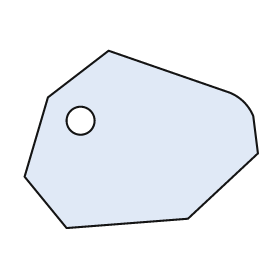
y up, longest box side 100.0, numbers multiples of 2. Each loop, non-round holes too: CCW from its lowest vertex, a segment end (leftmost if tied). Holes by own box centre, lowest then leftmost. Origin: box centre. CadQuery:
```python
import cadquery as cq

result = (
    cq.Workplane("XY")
    .moveTo(-32.0, -38.0)
    .lineTo(20.0, -34.0)
    .lineTo(50.0, -6.0)
    .lineTo(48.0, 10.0)
    .threePointArc((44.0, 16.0), (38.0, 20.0))
    .lineTo(-14.0, 38.0)
    .lineTo(-40.0, 18.0)
    .lineTo(-50.0, -16.0)
    .close()
    .moveTo(-26.0, 8.0)
    .circle(6.0)
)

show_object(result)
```